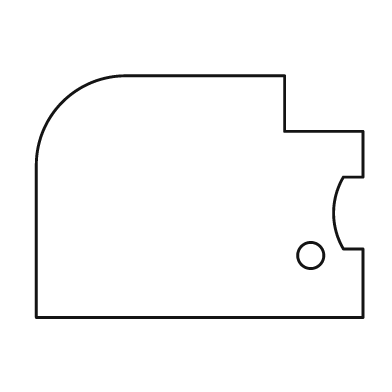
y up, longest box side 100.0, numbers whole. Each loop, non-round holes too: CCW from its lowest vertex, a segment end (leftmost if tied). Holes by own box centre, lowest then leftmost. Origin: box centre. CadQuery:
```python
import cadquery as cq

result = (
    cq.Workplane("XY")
    .moveTo(-50.0, -37.0)
    .lineTo(50.0, -37.0)
    .lineTo(50.0, -16.0)
    .lineTo(44.0, -16.0)
    .threePointArc((41.0, -5.0), (44.0, 6.0))
    .lineTo(50.0, 6.0)
    .lineTo(50.0, 20.0)
    .lineTo(26.0, 20.0)
    .lineTo(26.0, 37.0)
    .lineTo(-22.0, 37.0)
    .threePointArc((-42.0, 29.0), (-50.0, 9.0))
    .close()
    .moveTo(34.0, -18.0)
    .circle(4.0)
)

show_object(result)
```